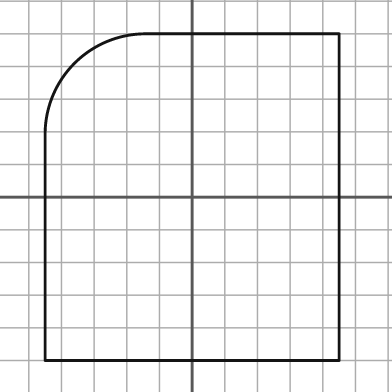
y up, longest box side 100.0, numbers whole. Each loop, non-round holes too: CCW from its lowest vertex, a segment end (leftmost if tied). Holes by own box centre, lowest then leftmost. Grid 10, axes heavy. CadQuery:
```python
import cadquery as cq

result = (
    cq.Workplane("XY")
    .moveTo(-45.0, -50.0)
    .lineTo(45.0, -50.0)
    .lineTo(45.0, 50.0)
    .lineTo(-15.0, 50.0)
    .threePointArc((-36.0, 41.0), (-45.0, 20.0))
    .close()
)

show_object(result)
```